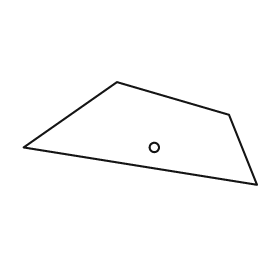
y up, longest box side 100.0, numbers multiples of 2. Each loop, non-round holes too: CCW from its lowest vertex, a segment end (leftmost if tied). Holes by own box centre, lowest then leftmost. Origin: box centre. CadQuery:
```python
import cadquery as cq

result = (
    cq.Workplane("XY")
    .moveTo(50.0, -22.0)
    .lineTo(38.0, 8.0)
    .lineTo(-10.0, 22.0)
    .lineTo(-50.0, -6.0)
    .close()
    .moveTo(6.0, -6.0)
    .circle(2.0)
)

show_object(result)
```